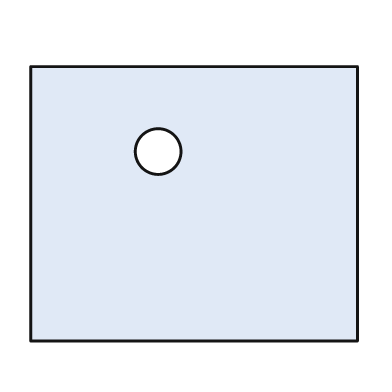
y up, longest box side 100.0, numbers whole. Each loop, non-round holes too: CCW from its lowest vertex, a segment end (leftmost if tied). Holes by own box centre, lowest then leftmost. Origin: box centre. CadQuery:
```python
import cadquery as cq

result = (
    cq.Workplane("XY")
    .moveTo(-50.0, -42.0)
    .lineTo(50.0, -42.0)
    .lineTo(50.0, 42.0)
    .lineTo(-50.0, 42.0)
    .close()
    .moveTo(-11.0, 16.0)
    .circle(7.0)
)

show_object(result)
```